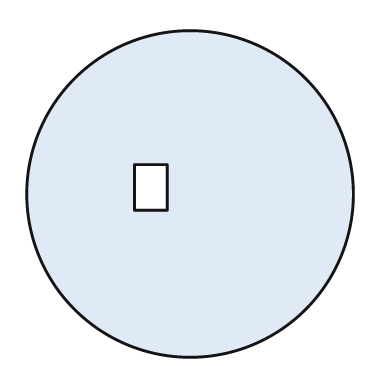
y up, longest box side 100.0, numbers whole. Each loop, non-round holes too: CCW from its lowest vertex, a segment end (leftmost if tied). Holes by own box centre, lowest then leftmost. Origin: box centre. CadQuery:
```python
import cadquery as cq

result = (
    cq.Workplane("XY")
    .moveTo(0.0, 0.0)
    .circle(50.0)
    .moveTo(-17.0, -5.0)
    .lineTo(-7.0, -5.0)
    .lineTo(-7.0, 9.0)
    .lineTo(-17.0, 9.0)
    .close()
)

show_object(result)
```